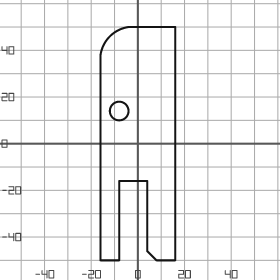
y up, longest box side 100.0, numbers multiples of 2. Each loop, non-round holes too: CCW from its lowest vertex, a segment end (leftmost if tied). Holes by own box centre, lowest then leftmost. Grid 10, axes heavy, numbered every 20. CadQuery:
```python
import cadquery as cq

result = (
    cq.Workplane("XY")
    .moveTo(-16.0, -50.0)
    .lineTo(-8.0, -50.0)
    .lineTo(-8.0, -16.0)
    .lineTo(4.0, -16.0)
    .lineTo(4.0, -46.0)
    .lineTo(8.0, -50.0)
    .lineTo(16.0, -50.0)
    .lineTo(16.0, 50.0)
    .lineTo(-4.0, 50.0)
    .threePointArc((-12.0, 46.0), (-16.0, 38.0))
    .close()
    .moveTo(-8.0, 14.0)
    .circle(4.0)
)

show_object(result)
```